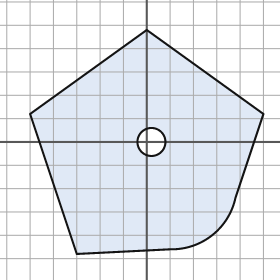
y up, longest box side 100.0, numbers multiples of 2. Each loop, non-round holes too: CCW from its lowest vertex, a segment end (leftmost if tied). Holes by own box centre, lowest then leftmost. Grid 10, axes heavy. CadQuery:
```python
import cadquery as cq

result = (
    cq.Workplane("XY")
    .moveTo(-30.0, -48.0)
    .lineTo(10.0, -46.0)
    .threePointArc((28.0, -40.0), (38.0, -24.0))
    .lineTo(50.0, 12.0)
    .lineTo(0.0, 48.0)
    .lineTo(-50.0, 12.0)
    .close()
    .moveTo(2.0, 0.0)
    .circle(6.0)
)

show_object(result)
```